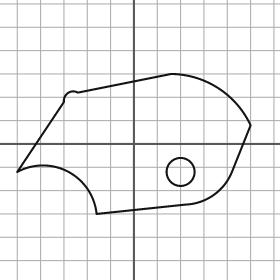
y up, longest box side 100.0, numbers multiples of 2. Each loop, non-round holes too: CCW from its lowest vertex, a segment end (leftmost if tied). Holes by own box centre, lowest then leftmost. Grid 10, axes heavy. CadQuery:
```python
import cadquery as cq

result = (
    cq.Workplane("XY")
    .moveTo(-16.0, -30.0)
    .lineTo(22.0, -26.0)
    .threePointArc((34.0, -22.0), (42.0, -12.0))
    .lineTo(50.0, 8.0)
    .threePointArc((36.0, 24.0), (16.0, 30.0))
    .lineTo(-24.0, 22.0)
    .threePointArc((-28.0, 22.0), (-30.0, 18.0))
    .lineTo(-50.0, -12.0)
    .threePointArc((-28.0, -12.0), (-16.0, -30.0))
    .close()
    .moveTo(20.0, -12.0)
    .circle(6.0)
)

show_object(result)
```